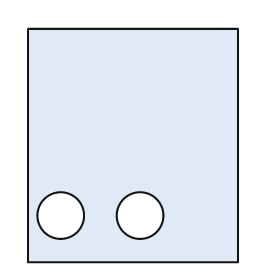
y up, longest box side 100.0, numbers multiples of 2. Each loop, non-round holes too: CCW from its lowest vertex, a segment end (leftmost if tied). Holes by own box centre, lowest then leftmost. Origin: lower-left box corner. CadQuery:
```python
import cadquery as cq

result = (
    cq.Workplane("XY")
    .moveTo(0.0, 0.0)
    .lineTo(90.0, 0.0)
    .lineTo(90.0, 100.0)
    .lineTo(0.0, 100.0)
    .close()
    .moveTo(14.0, 20.0)
    .circle(10.0)
    .moveTo(48.0, 20.0)
    .circle(10.0)
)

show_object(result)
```